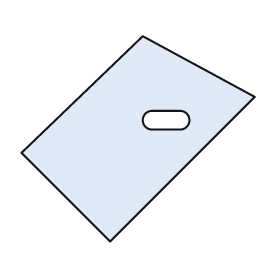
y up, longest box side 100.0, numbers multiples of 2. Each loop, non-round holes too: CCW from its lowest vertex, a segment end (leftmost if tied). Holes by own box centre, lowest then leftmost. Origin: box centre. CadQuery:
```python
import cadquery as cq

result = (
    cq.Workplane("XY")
    .moveTo(-12.0, -44.0)
    .lineTo(50.0, 18.0)
    .lineTo(2.0, 44.0)
    .lineTo(-50.0, -6.0)
    .close()
    .moveTo(6.0, 4.0)
    .lineTo(18.0, 4.0)
    .threePointArc((22.0, 8.0), (18.0, 12.0))
    .lineTo(6.0, 12.0)
    .threePointArc((2.0, 8.0), (6.0, 4.0))
    .close()
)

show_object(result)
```